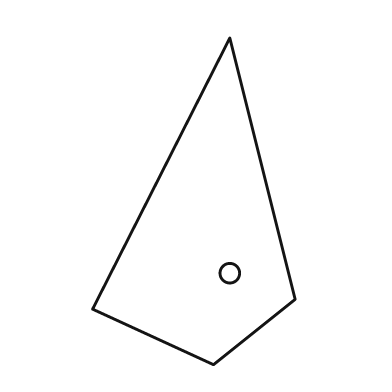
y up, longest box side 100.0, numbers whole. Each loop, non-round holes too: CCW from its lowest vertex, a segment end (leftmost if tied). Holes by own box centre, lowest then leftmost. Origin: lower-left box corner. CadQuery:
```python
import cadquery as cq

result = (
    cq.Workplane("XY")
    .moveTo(37.0, 0.0)
    .lineTo(62.0, 20.0)
    .lineTo(42.0, 100.0)
    .lineTo(0.0, 17.0)
    .close()
    .moveTo(42.0, 28.0)
    .circle(3.0)
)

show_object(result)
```